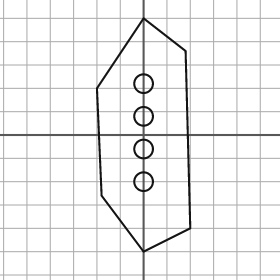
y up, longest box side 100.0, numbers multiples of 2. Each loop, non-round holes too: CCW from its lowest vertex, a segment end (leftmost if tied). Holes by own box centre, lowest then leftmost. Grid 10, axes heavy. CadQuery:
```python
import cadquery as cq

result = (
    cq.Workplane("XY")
    .moveTo(0.0, -50.0)
    .lineTo(20.0, -40.0)
    .lineTo(18.0, 36.0)
    .lineTo(0.0, 50.0)
    .lineTo(-20.0, 20.0)
    .lineTo(-18.0, -26.0)
    .close()
    .moveTo(0.0, -20.0)
    .circle(4.0)
    .moveTo(0.0, -6.0)
    .circle(4.0)
    .moveTo(0.0, 8.0)
    .circle(4.0)
    .moveTo(0.0, 22.0)
    .circle(4.0)
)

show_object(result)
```